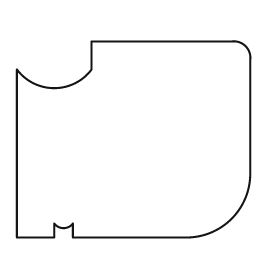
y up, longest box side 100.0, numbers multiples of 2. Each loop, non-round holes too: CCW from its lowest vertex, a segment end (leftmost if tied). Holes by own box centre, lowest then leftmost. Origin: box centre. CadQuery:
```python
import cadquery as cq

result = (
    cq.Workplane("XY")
    .moveTo(-50.0, -42.0)
    .lineTo(-34.0, -42.0)
    .lineTo(-34.0, -36.0)
    .threePointArc((-30.0, -38.0), (-26.0, -36.0))
    .lineTo(-26.0, -42.0)
    .lineTo(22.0, -42.0)
    .threePointArc((42.0, -34.0), (50.0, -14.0))
    .lineTo(50.0, 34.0)
    .threePointArc((48.0, 40.0), (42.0, 42.0))
    .lineTo(-18.0, 42.0)
    .lineTo(-18.0, 30.0)
    .threePointArc((-34.0, 22.0), (-50.0, 30.0))
    .close()
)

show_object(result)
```